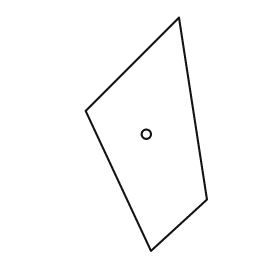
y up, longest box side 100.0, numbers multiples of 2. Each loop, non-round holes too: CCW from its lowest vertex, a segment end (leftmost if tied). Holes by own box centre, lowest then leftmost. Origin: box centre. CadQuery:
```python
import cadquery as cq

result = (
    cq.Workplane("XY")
    .moveTo(2.0, -50.0)
    .lineTo(26.0, -28.0)
    .lineTo(14.0, 50.0)
    .lineTo(-26.0, 10.0)
    .close()
    .moveTo(0.0, 0.0)
    .circle(2.0)
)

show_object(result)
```